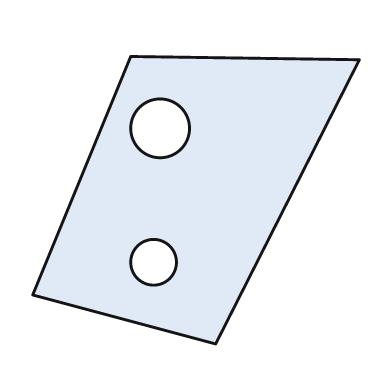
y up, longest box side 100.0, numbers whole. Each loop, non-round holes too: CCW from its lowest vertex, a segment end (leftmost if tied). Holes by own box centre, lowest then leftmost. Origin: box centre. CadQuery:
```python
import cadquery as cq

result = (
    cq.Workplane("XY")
    .moveTo(6.0, -44.0)
    .lineTo(50.0, 43.0)
    .lineTo(-20.0, 44.0)
    .lineTo(-50.0, -29.0)
    .close()
    .moveTo(-13.0, -19.0)
    .circle(7.0)
    .moveTo(-11.0, 22.0)
    .circle(9.0)
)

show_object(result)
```